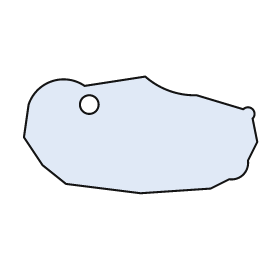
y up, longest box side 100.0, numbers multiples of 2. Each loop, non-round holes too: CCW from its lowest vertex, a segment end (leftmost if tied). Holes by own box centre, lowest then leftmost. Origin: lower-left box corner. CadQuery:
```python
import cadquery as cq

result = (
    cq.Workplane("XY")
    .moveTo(50.0, 0.0)
    .lineTo(80.0, 2.0)
    .lineTo(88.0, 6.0)
    .threePointArc((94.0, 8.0), (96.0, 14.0))
    .lineTo(100.0, 22.0)
    .lineTo(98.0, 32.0)
    .threePointArc((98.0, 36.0), (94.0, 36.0))
    .lineTo(74.0, 42.0)
    .threePointArc((62.0, 44.0), (52.0, 50.0))
    .lineTo(26.0, 46.0)
    .threePointArc((12.0, 48.0), (2.0, 38.0))
    .lineTo(0.0, 24.0)
    .lineTo(8.0, 12.0)
    .lineTo(18.0, 4.0)
    .close()
    .moveTo(28.0, 38.0)
    .circle(4.0)
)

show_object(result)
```